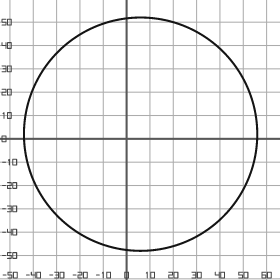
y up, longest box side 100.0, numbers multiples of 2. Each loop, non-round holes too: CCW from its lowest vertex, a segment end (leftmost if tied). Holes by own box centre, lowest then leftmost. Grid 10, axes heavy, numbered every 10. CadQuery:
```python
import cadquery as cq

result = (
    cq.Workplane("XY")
    .moveTo(6.0, 2.0)
    .circle(50.0)
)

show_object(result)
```